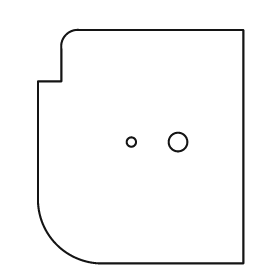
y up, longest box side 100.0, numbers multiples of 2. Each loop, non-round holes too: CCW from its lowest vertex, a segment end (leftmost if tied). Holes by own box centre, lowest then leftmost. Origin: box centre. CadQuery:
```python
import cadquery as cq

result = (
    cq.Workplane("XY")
    .moveTo(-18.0, -50.0)
    .lineTo(44.0, -50.0)
    .lineTo(44.0, 50.0)
    .lineTo(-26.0, 50.0)
    .threePointArc((-32.0, 48.0), (-34.0, 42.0))
    .lineTo(-34.0, 28.0)
    .lineTo(-44.0, 28.0)
    .lineTo(-44.0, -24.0)
    .threePointArc((-36.0, -42.0), (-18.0, -50.0))
    .close()
    .moveTo(-4.0, 2.0)
    .circle(2.0)
    .moveTo(16.0, 2.0)
    .circle(4.0)
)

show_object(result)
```